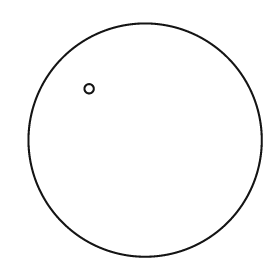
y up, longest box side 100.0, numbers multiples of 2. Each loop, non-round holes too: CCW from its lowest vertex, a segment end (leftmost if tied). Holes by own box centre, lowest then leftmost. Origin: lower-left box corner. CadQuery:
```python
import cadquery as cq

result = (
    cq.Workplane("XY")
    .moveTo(50.0, 50.0)
    .circle(50.0)
    .moveTo(26.0, 72.0)
    .circle(2.0)
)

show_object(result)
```